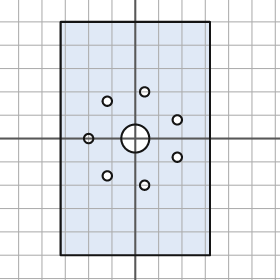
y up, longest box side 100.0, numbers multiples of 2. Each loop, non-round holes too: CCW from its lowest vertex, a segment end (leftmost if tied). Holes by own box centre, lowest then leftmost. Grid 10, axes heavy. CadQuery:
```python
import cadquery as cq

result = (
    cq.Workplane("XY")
    .moveTo(-32.0, -50.0)
    .lineTo(32.0, -50.0)
    .lineTo(32.0, 50.0)
    .lineTo(-32.0, 50.0)
    .close()
    .moveTo(4.0, -20.0)
    .circle(2.0)
    .moveTo(-12.0, -16.0)
    .circle(2.0)
    .moveTo(18.0, -8.0)
    .circle(2.0)
    .moveTo(-20.0, 0.0)
    .circle(2.0)
    .moveTo(0.0, 0.0)
    .circle(6.0)
    .moveTo(18.0, 8.0)
    .circle(2.0)
    .moveTo(-12.0, 16.0)
    .circle(2.0)
    .moveTo(4.0, 20.0)
    .circle(2.0)
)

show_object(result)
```